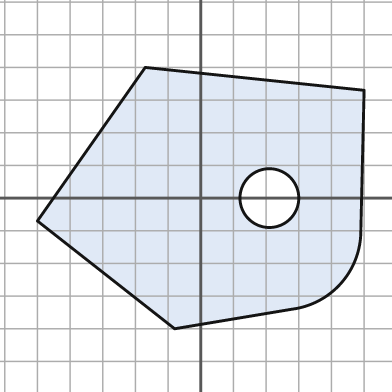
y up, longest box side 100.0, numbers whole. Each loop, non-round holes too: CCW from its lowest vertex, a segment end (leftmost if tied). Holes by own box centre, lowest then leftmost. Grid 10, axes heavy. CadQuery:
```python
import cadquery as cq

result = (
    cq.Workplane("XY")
    .moveTo(-8.0, -40.0)
    .lineTo(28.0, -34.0)
    .threePointArc((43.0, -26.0), (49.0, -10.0))
    .lineTo(50.0, 33.0)
    .lineTo(-17.0, 40.0)
    .lineTo(-50.0, -7.0)
    .close()
    .moveTo(21.0, 0.0)
    .circle(9.0)
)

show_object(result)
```